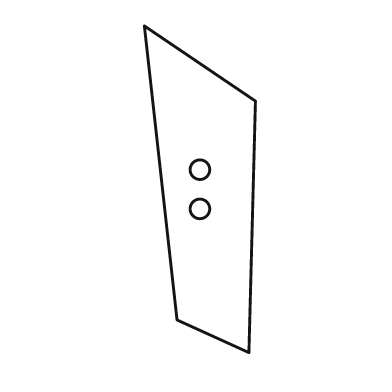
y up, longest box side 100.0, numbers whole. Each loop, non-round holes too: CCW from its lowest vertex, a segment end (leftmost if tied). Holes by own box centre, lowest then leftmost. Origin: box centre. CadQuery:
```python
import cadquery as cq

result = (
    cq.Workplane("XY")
    .moveTo(15.0, -50.0)
    .lineTo(17.0, 27.0)
    .lineTo(-17.0, 50.0)
    .lineTo(-7.0, -40.0)
    .close()
    .moveTo(0.0, -6.0)
    .circle(3.0)
    .moveTo(0.0, 6.0)
    .circle(3.0)
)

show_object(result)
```